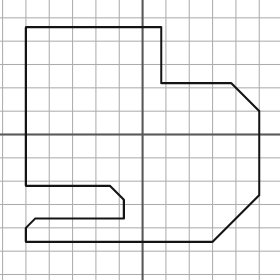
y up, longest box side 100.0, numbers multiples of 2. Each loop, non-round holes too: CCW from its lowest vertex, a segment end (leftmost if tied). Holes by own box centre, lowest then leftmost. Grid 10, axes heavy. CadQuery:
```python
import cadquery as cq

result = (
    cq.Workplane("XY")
    .moveTo(-50.0, -46.0)
    .lineTo(30.0, -46.0)
    .lineTo(50.0, -26.0)
    .lineTo(50.0, 10.0)
    .lineTo(38.0, 22.0)
    .lineTo(8.0, 22.0)
    .lineTo(8.0, 46.0)
    .lineTo(-50.0, 46.0)
    .lineTo(-50.0, -22.0)
    .lineTo(-14.0, -22.0)
    .lineTo(-8.0, -28.0)
    .lineTo(-8.0, -36.0)
    .lineTo(-46.0, -36.0)
    .lineTo(-50.0, -40.0)
    .close()
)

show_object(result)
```